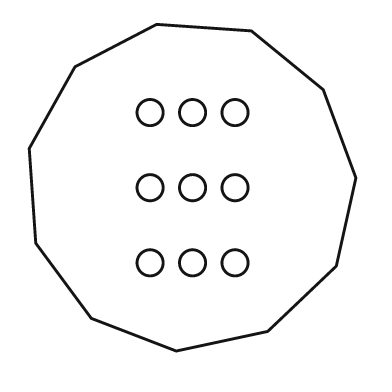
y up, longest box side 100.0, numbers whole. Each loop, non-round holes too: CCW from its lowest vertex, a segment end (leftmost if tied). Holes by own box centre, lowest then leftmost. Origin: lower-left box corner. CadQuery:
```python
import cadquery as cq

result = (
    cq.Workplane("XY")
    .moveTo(45.0, 0.0)
    .lineTo(73.0, 6.0)
    .lineTo(94.0, 26.0)
    .lineTo(100.0, 53.0)
    .lineTo(90.0, 80.0)
    .lineTo(68.0, 98.0)
    .lineTo(39.0, 100.0)
    .lineTo(14.0, 87.0)
    .lineTo(0.0, 62.0)
    .lineTo(2.0, 33.0)
    .lineTo(19.0, 10.0)
    .close()
    .moveTo(37.0, 27.0)
    .circle(4.0)
    .moveTo(50.0, 27.0)
    .circle(4.0)
    .moveTo(63.0, 27.0)
    .circle(4.0)
    .moveTo(37.0, 50.0)
    .circle(4.0)
    .moveTo(50.0, 50.0)
    .circle(4.0)
    .moveTo(63.0, 50.0)
    .circle(4.0)
    .moveTo(37.0, 73.0)
    .circle(4.0)
    .moveTo(50.0, 73.0)
    .circle(4.0)
    .moveTo(63.0, 73.0)
    .circle(4.0)
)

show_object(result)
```